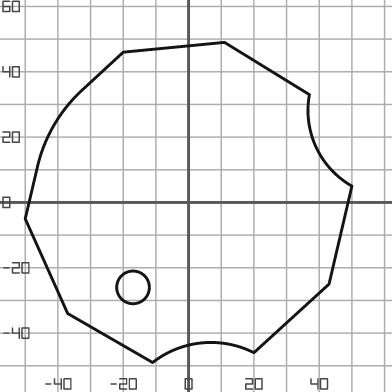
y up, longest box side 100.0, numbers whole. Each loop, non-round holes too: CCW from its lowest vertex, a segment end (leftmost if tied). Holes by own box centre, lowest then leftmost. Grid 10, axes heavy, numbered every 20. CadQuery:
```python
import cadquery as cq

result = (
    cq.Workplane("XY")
    .moveTo(-11.0, -49.0)
    .threePointArc((4.0, -43.0), (20.0, -46.0))
    .lineTo(43.0, -25.0)
    .lineTo(50.0, 5.0)
    .threePointArc((39.0, 17.0), (37.0, 33.0))
    .lineTo(11.0, 49.0)
    .lineTo(-20.0, 46.0)
    .lineTo(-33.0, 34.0)
    .threePointArc((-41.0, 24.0), (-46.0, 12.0))
    .lineTo(-50.0, -5.0)
    .lineTo(-37.0, -34.0)
    .close()
    .moveTo(-17.0, -26.0)
    .circle(5.0)
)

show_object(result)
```